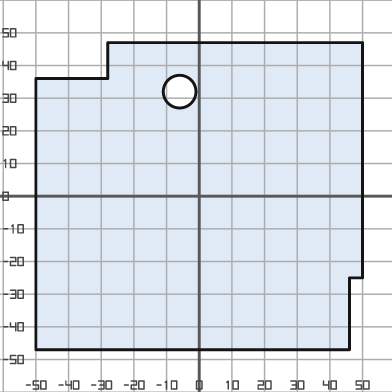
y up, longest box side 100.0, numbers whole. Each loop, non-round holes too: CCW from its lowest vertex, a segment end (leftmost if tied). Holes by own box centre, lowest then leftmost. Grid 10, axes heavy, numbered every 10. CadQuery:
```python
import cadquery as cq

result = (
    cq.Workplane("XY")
    .moveTo(-50.0, -47.0)
    .lineTo(46.0, -47.0)
    .lineTo(46.0, -25.0)
    .lineTo(50.0, -25.0)
    .lineTo(50.0, 47.0)
    .lineTo(-28.0, 47.0)
    .lineTo(-28.0, 36.0)
    .lineTo(-50.0, 36.0)
    .close()
    .moveTo(-6.0, 32.0)
    .circle(5.0)
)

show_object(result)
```